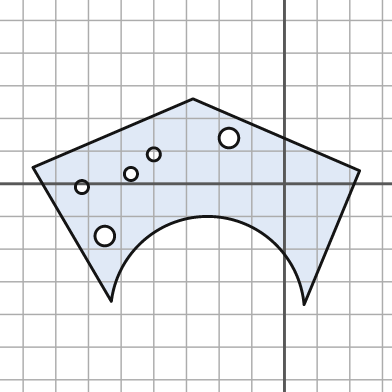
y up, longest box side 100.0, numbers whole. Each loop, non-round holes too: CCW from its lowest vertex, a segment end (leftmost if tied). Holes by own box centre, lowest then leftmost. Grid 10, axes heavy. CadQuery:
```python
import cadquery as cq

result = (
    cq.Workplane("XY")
    .moveTo(6.0, -37.0)
    .lineTo(23.0, 4.0)
    .lineTo(-28.0, 26.0)
    .lineTo(-77.0, 5.0)
    .lineTo(-53.0, -36.0)
    .threePointArc((-23.0, -10.0), (6.0, -37.0))
    .close()
    .moveTo(-55.0, -16.0)
    .circle(3.0)
    .moveTo(-62.0, -1.0)
    .circle(2.0)
    .moveTo(-47.0, 3.0)
    .circle(2.0)
    .moveTo(-40.0, 9.0)
    .circle(2.0)
    .moveTo(-17.0, 14.0)
    .circle(3.0)
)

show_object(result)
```